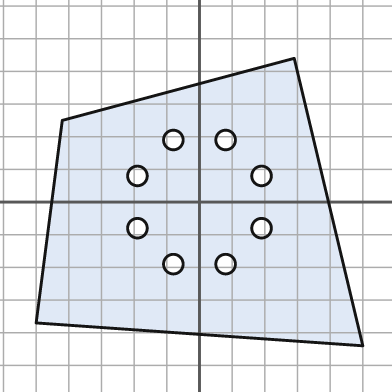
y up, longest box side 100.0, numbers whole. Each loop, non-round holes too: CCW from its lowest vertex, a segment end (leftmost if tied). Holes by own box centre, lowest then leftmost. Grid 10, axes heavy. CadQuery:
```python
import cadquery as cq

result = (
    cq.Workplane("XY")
    .moveTo(50.0, -44.0)
    .lineTo(29.0, 44.0)
    .lineTo(-42.0, 25.0)
    .lineTo(-50.0, -37.0)
    .close()
    .moveTo(-8.0, -19.0)
    .circle(3.0)
    .moveTo(8.0, -19.0)
    .circle(3.0)
    .moveTo(-19.0, -8.0)
    .circle(3.0)
    .moveTo(19.0, -8.0)
    .circle(3.0)
    .moveTo(-19.0, 8.0)
    .circle(3.0)
    .moveTo(19.0, 8.0)
    .circle(3.0)
    .moveTo(-8.0, 19.0)
    .circle(3.0)
    .moveTo(8.0, 19.0)
    .circle(3.0)
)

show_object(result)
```